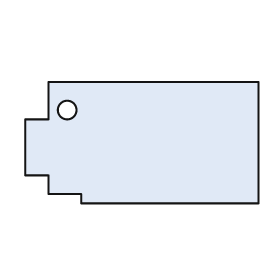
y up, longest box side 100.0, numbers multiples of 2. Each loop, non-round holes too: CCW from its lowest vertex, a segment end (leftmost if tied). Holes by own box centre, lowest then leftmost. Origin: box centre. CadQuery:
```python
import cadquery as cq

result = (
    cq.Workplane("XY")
    .moveTo(-26.0, -26.0)
    .lineTo(50.0, -26.0)
    .lineTo(50.0, 26.0)
    .lineTo(-40.0, 26.0)
    .lineTo(-40.0, 10.0)
    .lineTo(-50.0, 10.0)
    .lineTo(-50.0, -14.0)
    .lineTo(-40.0, -14.0)
    .lineTo(-40.0, -22.0)
    .lineTo(-26.0, -22.0)
    .close()
    .moveTo(-32.0, 14.0)
    .circle(4.0)
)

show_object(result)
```